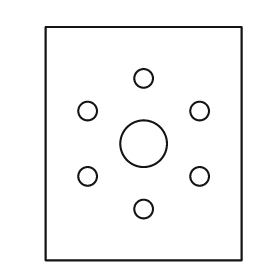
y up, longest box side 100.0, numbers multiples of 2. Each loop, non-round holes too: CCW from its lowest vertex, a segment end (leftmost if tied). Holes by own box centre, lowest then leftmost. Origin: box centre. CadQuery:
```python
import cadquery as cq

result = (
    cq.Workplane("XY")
    .moveTo(-42.0, -50.0)
    .lineTo(42.0, -50.0)
    .lineTo(42.0, 50.0)
    .lineTo(-42.0, 50.0)
    .close()
    .moveTo(0.0, -28.0)
    .circle(4.0)
    .moveTo(-24.0, -14.0)
    .circle(4.0)
    .moveTo(24.0, -14.0)
    .circle(4.0)
    .moveTo(0.0, 0.0)
    .circle(10.0)
    .moveTo(-24.0, 14.0)
    .circle(4.0)
    .moveTo(24.0, 14.0)
    .circle(4.0)
    .moveTo(0.0, 28.0)
    .circle(4.0)
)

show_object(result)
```